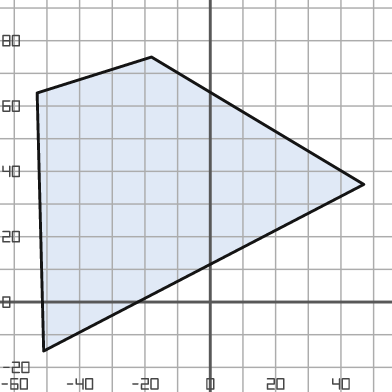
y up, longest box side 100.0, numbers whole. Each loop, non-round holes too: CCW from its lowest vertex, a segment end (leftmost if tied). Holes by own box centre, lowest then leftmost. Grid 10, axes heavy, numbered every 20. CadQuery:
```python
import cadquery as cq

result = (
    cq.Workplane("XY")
    .moveTo(-51.0, -15.0)
    .lineTo(47.0, 36.0)
    .lineTo(-18.0, 75.0)
    .lineTo(-53.0, 64.0)
    .close()
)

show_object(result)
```